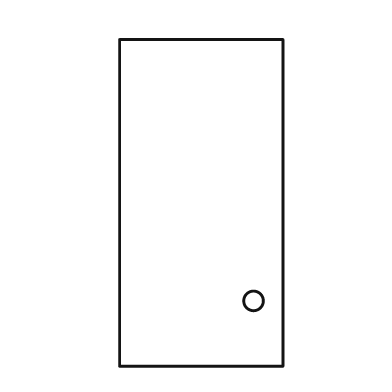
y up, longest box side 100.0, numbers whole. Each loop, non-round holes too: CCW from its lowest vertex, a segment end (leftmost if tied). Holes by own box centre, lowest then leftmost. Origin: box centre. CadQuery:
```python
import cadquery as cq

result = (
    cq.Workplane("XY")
    .moveTo(-25.0, -50.0)
    .lineTo(25.0, -50.0)
    .lineTo(25.0, 50.0)
    .lineTo(-25.0, 50.0)
    .close()
    .moveTo(16.0, -30.0)
    .circle(3.0)
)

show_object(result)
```